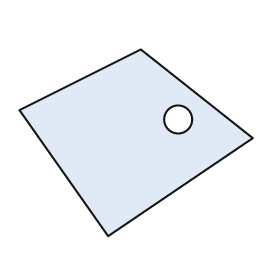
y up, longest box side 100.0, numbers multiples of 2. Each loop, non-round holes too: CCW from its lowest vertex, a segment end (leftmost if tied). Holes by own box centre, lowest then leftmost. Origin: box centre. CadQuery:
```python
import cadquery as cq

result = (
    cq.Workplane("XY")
    .moveTo(-12.0, -40.0)
    .lineTo(50.0, 2.0)
    .lineTo(2.0, 40.0)
    .lineTo(-50.0, 14.0)
    .close()
    .moveTo(18.0, 10.0)
    .circle(6.0)
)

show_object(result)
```